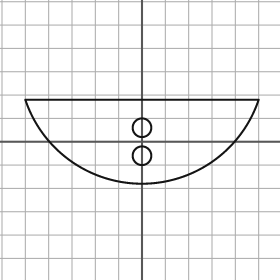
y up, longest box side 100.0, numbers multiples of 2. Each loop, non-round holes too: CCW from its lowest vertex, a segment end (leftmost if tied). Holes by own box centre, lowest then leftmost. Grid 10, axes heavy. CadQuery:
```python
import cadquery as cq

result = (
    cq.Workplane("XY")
    .moveTo(-50.0, 18.0)
    .threePointArc((0.0, -18.0), (50.0, 18.0))
    .close()
    .moveTo(0.0, -6.0)
    .circle(4.0)
    .moveTo(0.0, 6.0)
    .circle(4.0)
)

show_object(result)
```